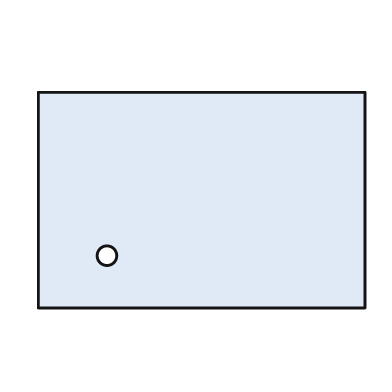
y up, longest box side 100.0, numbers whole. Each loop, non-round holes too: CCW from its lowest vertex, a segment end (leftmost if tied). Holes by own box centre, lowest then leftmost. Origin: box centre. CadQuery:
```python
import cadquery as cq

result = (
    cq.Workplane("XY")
    .moveTo(-50.0, -33.0)
    .lineTo(50.0, -33.0)
    .lineTo(50.0, 33.0)
    .lineTo(-50.0, 33.0)
    .close()
    .moveTo(-29.0, -17.0)
    .circle(3.0)
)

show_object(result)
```